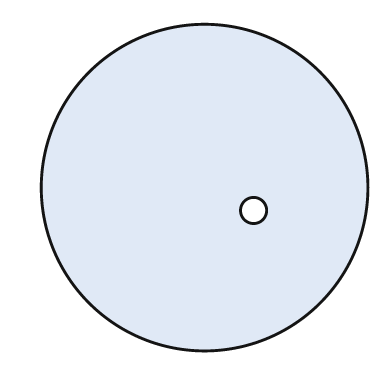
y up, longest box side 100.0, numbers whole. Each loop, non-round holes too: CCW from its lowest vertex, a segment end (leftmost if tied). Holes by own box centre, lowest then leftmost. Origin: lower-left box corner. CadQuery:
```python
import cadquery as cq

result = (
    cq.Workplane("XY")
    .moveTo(50.0, 50.0)
    .circle(50.0)
    .moveTo(65.0, 43.0)
    .circle(4.0)
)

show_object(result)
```